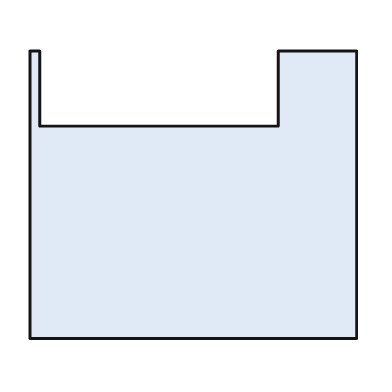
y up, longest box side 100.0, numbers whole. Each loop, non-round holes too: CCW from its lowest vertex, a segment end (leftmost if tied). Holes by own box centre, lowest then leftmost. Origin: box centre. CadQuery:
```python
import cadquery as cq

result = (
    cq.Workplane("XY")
    .moveTo(-50.0, -44.0)
    .lineTo(50.0, -44.0)
    .lineTo(50.0, 44.0)
    .lineTo(26.0, 44.0)
    .lineTo(26.0, 21.0)
    .lineTo(-47.0, 21.0)
    .lineTo(-47.0, 44.0)
    .lineTo(-50.0, 44.0)
    .close()
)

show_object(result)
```